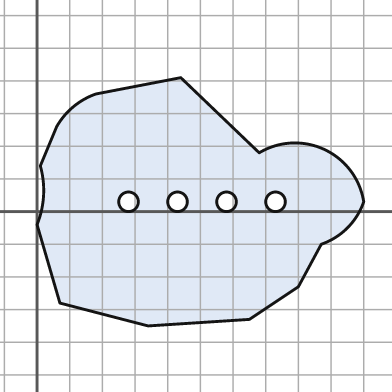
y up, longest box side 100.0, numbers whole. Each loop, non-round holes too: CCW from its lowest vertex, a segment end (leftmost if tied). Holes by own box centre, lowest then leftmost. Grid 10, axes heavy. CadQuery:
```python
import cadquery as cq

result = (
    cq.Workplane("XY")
    .moveTo(34.0, -35.0)
    .lineTo(65.0, -33.0)
    .lineTo(80.0, -23.0)
    .lineTo(87.0, -10.0)
    .threePointArc((95.0, -5.0), (100.0, 3.0))
    .threePointArc((88.0, 19.0), (68.0, 18.0))
    .lineTo(44.0, 41.0)
    .lineTo(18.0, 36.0)
    .threePointArc((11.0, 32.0), (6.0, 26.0))
    .lineTo(1.0, 14.0)
    .threePointArc((2.0, 5.0), (0.0, -4.0))
    .lineTo(7.0, -28.0)
    .close()
    .moveTo(28.0, 3.0)
    .circle(3.0)
    .moveTo(43.0, 3.0)
    .circle(3.0)
    .moveTo(58.0, 3.0)
    .circle(3.0)
    .moveTo(73.0, 3.0)
    .circle(3.0)
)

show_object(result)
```